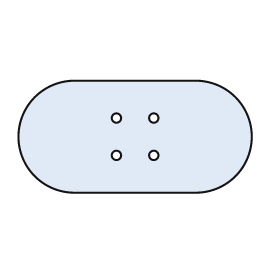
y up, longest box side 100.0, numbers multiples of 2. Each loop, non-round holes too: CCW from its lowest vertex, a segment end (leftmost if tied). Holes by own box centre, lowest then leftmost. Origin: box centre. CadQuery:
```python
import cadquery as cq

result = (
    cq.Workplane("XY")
    .moveTo(-26.0, -24.0)
    .lineTo(26.0, -24.0)
    .threePointArc((50.0, 0.0), (26.0, 24.0))
    .lineTo(-26.0, 24.0)
    .threePointArc((-50.0, 0.0), (-26.0, -24.0))
    .close()
    .moveTo(-8.0, -8.0)
    .circle(2.0)
    .moveTo(8.0, -8.0)
    .circle(2.0)
    .moveTo(-8.0, 8.0)
    .circle(2.0)
    .moveTo(8.0, 8.0)
    .circle(2.0)
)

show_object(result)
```